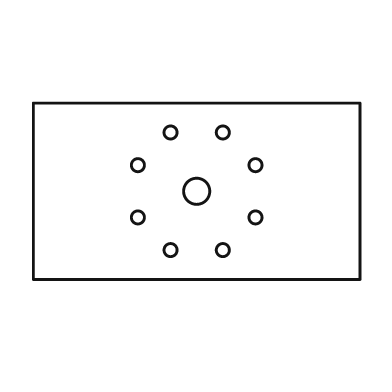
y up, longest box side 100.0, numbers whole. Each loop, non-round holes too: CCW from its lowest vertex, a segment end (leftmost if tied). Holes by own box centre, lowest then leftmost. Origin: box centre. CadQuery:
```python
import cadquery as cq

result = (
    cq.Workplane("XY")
    .moveTo(-50.0, -27.0)
    .lineTo(50.0, -27.0)
    .lineTo(50.0, 27.0)
    .lineTo(-50.0, 27.0)
    .close()
    .moveTo(-8.0, -18.0)
    .circle(2.0)
    .moveTo(8.0, -18.0)
    .circle(2.0)
    .moveTo(-18.0, -8.0)
    .circle(2.0)
    .moveTo(18.0, -8.0)
    .circle(2.0)
    .moveTo(0.0, 0.0)
    .circle(4.0)
    .moveTo(-18.0, 8.0)
    .circle(2.0)
    .moveTo(18.0, 8.0)
    .circle(2.0)
    .moveTo(-8.0, 18.0)
    .circle(2.0)
    .moveTo(8.0, 18.0)
    .circle(2.0)
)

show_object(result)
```